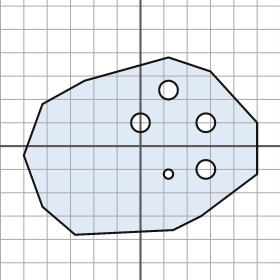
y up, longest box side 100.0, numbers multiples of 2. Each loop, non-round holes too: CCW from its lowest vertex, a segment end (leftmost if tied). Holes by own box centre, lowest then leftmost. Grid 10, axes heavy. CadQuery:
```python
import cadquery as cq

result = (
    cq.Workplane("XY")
    .moveTo(-28.0, -38.0)
    .lineTo(14.0, -36.0)
    .lineTo(26.0, -30.0)
    .lineTo(50.0, -12.0)
    .lineTo(50.0, 10.0)
    .lineTo(30.0, 32.0)
    .lineTo(12.0, 38.0)
    .lineTo(-24.0, 28.0)
    .lineTo(-42.0, 18.0)
    .lineTo(-50.0, -4.0)
    .lineTo(-42.0, -26.0)
    .close()
    .moveTo(12.0, -12.0)
    .circle(2.0)
    .moveTo(28.0, -10.0)
    .circle(4.0)
    .moveTo(0.0, 10.0)
    .circle(4.0)
    .moveTo(28.0, 10.0)
    .circle(4.0)
    .moveTo(12.0, 24.0)
    .circle(4.0)
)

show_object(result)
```